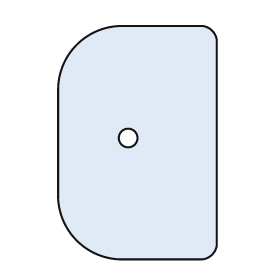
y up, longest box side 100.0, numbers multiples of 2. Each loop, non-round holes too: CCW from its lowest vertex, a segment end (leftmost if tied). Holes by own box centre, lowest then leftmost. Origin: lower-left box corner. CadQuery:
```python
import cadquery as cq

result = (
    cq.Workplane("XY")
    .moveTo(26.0, 0.0)
    .lineTo(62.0, 0.0)
    .threePointArc((66.0, 2.0), (68.0, 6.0))
    .lineTo(68.0, 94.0)
    .threePointArc((66.0, 98.0), (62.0, 100.0))
    .lineTo(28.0, 100.0)
    .threePointArc((8.0, 92.0), (0.0, 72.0))
    .lineTo(0.0, 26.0)
    .threePointArc((8.0, 8.0), (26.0, 0.0))
    .close()
    .moveTo(30.0, 52.0)
    .circle(4.0)
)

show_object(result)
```